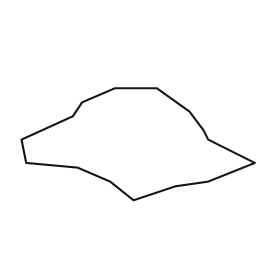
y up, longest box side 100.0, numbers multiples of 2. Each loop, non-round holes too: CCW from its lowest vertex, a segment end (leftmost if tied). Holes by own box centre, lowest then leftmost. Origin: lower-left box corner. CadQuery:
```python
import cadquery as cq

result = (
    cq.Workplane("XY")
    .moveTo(48.0, 0.0)
    .lineTo(66.0, 6.0)
    .lineTo(80.0, 8.0)
    .lineTo(100.0, 16.0)
    .lineTo(80.0, 26.0)
    .lineTo(78.0, 30.0)
    .lineTo(72.0, 38.0)
    .lineTo(58.0, 48.0)
    .lineTo(40.0, 48.0)
    .lineTo(26.0, 42.0)
    .lineTo(22.0, 36.0)
    .lineTo(0.0, 26.0)
    .lineTo(2.0, 16.0)
    .lineTo(24.0, 14.0)
    .lineTo(38.0, 8.0)
    .close()
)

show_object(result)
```